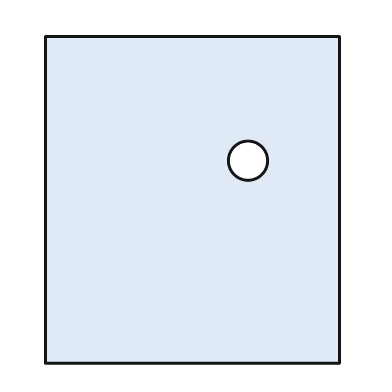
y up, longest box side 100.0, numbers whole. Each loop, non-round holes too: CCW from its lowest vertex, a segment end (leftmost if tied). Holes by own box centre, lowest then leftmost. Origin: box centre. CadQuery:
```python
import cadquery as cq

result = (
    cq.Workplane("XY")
    .moveTo(-45.0, -50.0)
    .lineTo(45.0, -50.0)
    .lineTo(45.0, 50.0)
    .lineTo(-45.0, 50.0)
    .close()
    .moveTo(17.0, 12.0)
    .circle(6.0)
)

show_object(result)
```